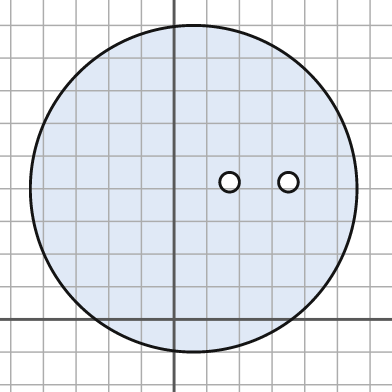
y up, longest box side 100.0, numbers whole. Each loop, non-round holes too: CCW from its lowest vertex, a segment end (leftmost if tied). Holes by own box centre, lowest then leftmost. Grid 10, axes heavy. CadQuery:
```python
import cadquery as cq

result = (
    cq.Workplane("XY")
    .moveTo(6.0, 40.0)
    .circle(50.0)
    .moveTo(17.0, 42.0)
    .circle(3.0)
    .moveTo(35.0, 42.0)
    .circle(3.0)
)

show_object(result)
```